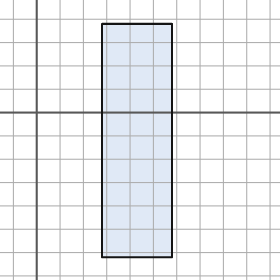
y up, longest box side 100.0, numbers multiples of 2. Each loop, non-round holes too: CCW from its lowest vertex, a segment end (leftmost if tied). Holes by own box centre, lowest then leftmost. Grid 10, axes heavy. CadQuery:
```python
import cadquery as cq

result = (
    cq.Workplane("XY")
    .moveTo(28.0, -62.0)
    .lineTo(58.0, -62.0)
    .lineTo(58.0, 38.0)
    .lineTo(28.0, 38.0)
    .close()
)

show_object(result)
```